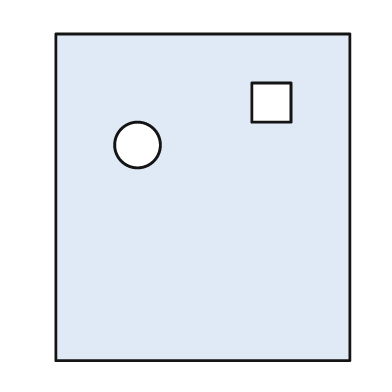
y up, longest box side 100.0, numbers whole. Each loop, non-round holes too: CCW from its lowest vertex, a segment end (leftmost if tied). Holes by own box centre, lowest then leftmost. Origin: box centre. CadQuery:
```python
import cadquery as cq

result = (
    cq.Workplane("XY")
    .moveTo(-45.0, -50.0)
    .lineTo(45.0, -50.0)
    .lineTo(45.0, 50.0)
    .lineTo(-45.0, 50.0)
    .close()
    .moveTo(-20.0, 16.0)
    .circle(7.0)
    .moveTo(15.0, 23.0)
    .lineTo(27.0, 23.0)
    .lineTo(27.0, 35.0)
    .lineTo(15.0, 35.0)
    .close()
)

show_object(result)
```